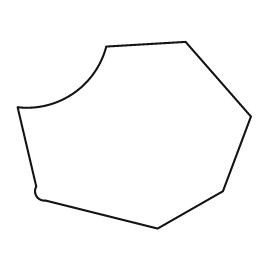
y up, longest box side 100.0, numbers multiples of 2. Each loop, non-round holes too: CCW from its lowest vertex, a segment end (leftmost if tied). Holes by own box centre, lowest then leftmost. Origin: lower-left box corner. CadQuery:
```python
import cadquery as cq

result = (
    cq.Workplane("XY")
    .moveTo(60.0, 0.0)
    .lineTo(88.0, 16.0)
    .lineTo(100.0, 48.0)
    .lineTo(72.0, 80.0)
    .lineTo(38.0, 78.0)
    .threePointArc((24.0, 58.0), (0.0, 52.0))
    .lineTo(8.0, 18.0)
    .threePointArc((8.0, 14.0), (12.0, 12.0))
    .close()
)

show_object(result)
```